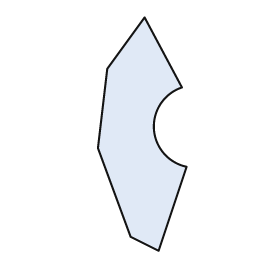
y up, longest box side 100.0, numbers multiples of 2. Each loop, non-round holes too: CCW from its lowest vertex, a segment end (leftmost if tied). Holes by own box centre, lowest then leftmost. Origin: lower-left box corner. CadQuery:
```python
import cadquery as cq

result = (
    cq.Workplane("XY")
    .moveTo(26.0, 0.0)
    .lineTo(38.0, 36.0)
    .threePointArc((24.0, 52.0), (36.0, 70.0))
    .lineTo(20.0, 100.0)
    .lineTo(4.0, 78.0)
    .lineTo(0.0, 44.0)
    .lineTo(14.0, 6.0)
    .close()
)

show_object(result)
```